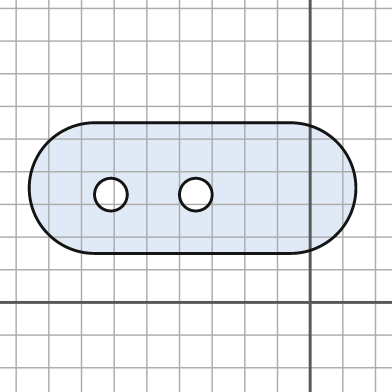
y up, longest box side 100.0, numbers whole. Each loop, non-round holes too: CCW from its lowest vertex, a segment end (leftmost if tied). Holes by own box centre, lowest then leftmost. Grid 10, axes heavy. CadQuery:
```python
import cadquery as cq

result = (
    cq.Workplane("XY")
    .moveTo(-66.0, 15.0)
    .lineTo(-6.0, 15.0)
    .threePointArc((14.0, 35.0), (-6.0, 55.0))
    .lineTo(-66.0, 55.0)
    .threePointArc((-86.0, 35.0), (-66.0, 15.0))
    .close()
    .moveTo(-61.0, 33.0)
    .circle(5.0)
    .moveTo(-35.0, 33.0)
    .circle(5.0)
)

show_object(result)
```